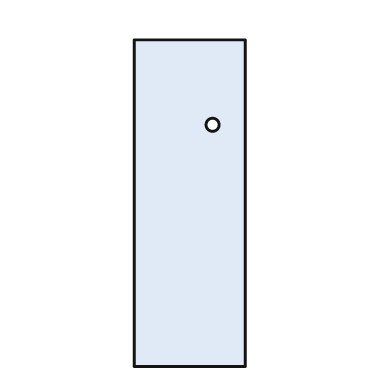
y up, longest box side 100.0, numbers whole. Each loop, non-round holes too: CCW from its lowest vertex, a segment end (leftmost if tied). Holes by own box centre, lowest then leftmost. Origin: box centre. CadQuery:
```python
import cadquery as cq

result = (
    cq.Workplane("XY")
    .moveTo(-17.0, -50.0)
    .lineTo(17.0, -50.0)
    .lineTo(17.0, 50.0)
    .lineTo(-17.0, 50.0)
    .close()
    .moveTo(7.0, 24.0)
    .circle(2.0)
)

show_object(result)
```